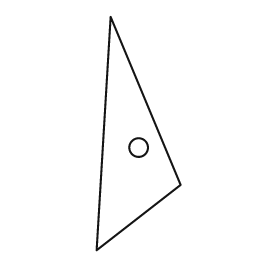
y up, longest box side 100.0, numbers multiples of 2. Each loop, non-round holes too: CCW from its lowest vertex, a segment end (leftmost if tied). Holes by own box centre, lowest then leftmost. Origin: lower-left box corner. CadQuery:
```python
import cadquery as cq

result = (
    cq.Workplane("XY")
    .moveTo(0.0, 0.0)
    .lineTo(36.0, 28.0)
    .lineTo(6.0, 100.0)
    .close()
    .moveTo(18.0, 44.0)
    .circle(4.0)
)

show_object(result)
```